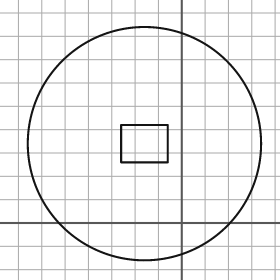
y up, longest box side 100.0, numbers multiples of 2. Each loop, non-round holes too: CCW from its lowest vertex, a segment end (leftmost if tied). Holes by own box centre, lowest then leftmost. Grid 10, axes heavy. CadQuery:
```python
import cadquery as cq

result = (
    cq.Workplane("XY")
    .moveTo(-16.0, 34.0)
    .circle(50.0)
    .moveTo(-26.0, 26.0)
    .lineTo(-6.0, 26.0)
    .lineTo(-6.0, 42.0)
    .lineTo(-26.0, 42.0)
    .close()
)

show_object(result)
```